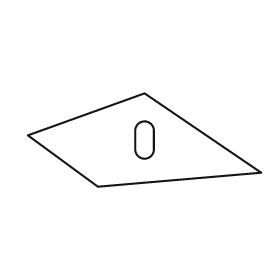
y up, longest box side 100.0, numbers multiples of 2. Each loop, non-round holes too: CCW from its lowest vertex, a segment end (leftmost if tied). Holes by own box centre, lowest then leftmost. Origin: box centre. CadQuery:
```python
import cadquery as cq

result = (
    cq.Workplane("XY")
    .moveTo(-20.0, -20.0)
    .lineTo(50.0, -14.0)
    .lineTo(0.0, 20.0)
    .lineTo(-50.0, 2.0)
    .close()
    .moveTo(-4.0, -4.0)
    .threePointArc((0.0, -8.0), (4.0, -4.0))
    .lineTo(4.0, 4.0)
    .threePointArc((0.0, 8.0), (-4.0, 4.0))
    .close()
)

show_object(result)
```